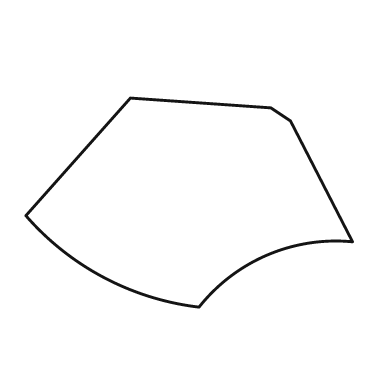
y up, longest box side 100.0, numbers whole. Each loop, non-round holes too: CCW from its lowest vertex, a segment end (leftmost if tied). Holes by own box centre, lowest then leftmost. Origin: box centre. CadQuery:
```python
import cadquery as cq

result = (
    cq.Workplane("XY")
    .moveTo(3.0, -32.0)
    .threePointArc((24.0, -16.0), (50.0, -12.0))
    .lineTo(31.0, 25.0)
    .lineTo(25.0, 29.0)
    .lineTo(-18.0, 32.0)
    .lineTo(-50.0, -4.0)
    .threePointArc((-26.0, -23.0), (3.0, -32.0))
    .close()
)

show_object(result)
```